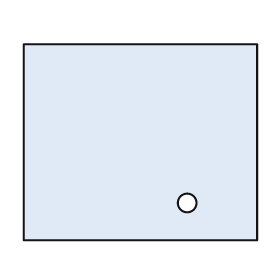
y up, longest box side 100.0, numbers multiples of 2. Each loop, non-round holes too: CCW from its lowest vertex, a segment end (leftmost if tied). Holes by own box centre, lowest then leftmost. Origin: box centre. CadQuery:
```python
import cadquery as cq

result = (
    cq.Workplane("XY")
    .moveTo(-50.0, -42.0)
    .lineTo(50.0, -42.0)
    .lineTo(50.0, 42.0)
    .lineTo(-50.0, 42.0)
    .close()
    .moveTo(20.0, -26.0)
    .circle(4.0)
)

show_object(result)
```